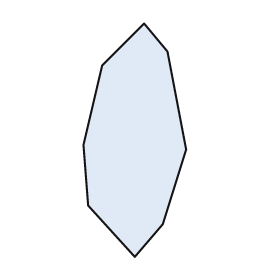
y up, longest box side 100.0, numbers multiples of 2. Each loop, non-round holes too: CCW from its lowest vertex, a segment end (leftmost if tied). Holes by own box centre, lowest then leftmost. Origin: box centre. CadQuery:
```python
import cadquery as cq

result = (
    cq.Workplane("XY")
    .moveTo(0.0, -50.0)
    .lineTo(12.0, -36.0)
    .lineTo(22.0, -4.0)
    .lineTo(14.0, 38.0)
    .lineTo(4.0, 50.0)
    .lineTo(-14.0, 32.0)
    .lineTo(-22.0, -2.0)
    .lineTo(-20.0, -28.0)
    .close()
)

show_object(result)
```